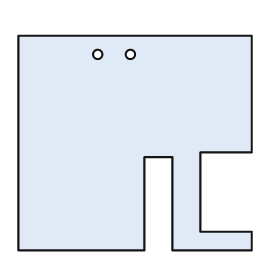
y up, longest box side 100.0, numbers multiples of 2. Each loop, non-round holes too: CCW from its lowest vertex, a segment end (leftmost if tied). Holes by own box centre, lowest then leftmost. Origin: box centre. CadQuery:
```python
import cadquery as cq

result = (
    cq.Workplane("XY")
    .moveTo(-50.0, -46.0)
    .lineTo(4.0, -46.0)
    .lineTo(4.0, -6.0)
    .lineTo(16.0, -6.0)
    .lineTo(16.0, -46.0)
    .lineTo(50.0, -46.0)
    .lineTo(50.0, -38.0)
    .lineTo(28.0, -38.0)
    .lineTo(28.0, -4.0)
    .lineTo(50.0, -4.0)
    .lineTo(50.0, 46.0)
    .lineTo(-50.0, 46.0)
    .close()
    .moveTo(-16.0, 38.0)
    .circle(2.0)
    .moveTo(-2.0, 38.0)
    .circle(2.0)
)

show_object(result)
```